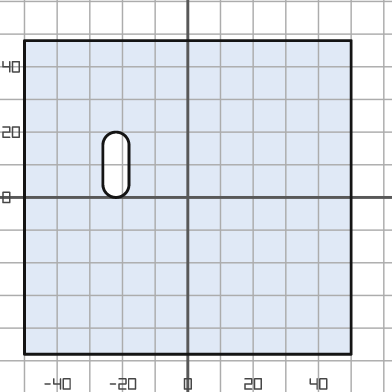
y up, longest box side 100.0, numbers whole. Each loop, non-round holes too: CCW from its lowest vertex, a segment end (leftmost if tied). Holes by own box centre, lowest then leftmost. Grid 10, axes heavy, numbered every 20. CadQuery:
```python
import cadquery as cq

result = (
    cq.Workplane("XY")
    .moveTo(-50.0, -48.0)
    .lineTo(50.0, -48.0)
    .lineTo(50.0, 48.0)
    .lineTo(-50.0, 48.0)
    .close()
    .moveTo(-26.0, 4.0)
    .threePointArc((-22.0, 0.0), (-18.0, 4.0))
    .lineTo(-18.0, 16.0)
    .threePointArc((-22.0, 20.0), (-26.0, 16.0))
    .close()
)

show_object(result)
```